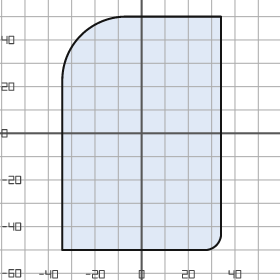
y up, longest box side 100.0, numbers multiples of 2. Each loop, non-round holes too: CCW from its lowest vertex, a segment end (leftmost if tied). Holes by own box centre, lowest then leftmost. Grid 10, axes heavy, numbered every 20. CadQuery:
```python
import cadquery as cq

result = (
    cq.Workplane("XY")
    .moveTo(-34.0, -50.0)
    .lineTo(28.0, -50.0)
    .threePointArc((32.0, -48.0), (34.0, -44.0))
    .lineTo(34.0, 50.0)
    .lineTo(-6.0, 50.0)
    .threePointArc((-26.0, 42.0), (-34.0, 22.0))
    .close()
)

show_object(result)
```